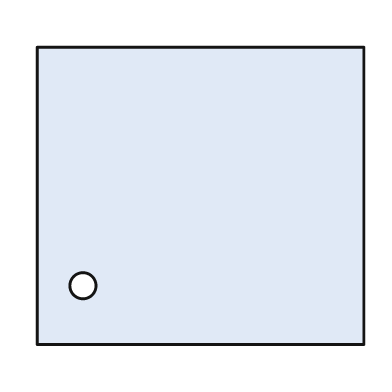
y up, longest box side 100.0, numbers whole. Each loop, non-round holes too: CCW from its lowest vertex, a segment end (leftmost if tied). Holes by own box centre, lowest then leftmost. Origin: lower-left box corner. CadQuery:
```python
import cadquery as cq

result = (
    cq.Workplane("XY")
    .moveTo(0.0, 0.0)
    .lineTo(100.0, 0.0)
    .lineTo(100.0, 91.0)
    .lineTo(0.0, 91.0)
    .close()
    .moveTo(14.0, 18.0)
    .circle(4.0)
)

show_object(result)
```